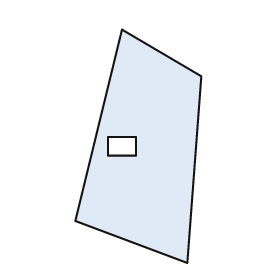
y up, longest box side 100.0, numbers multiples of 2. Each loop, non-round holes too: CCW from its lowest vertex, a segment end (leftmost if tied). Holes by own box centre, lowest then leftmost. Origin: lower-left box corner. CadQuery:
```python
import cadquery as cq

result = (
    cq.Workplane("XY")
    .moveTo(48.0, 0.0)
    .lineTo(54.0, 80.0)
    .lineTo(20.0, 100.0)
    .lineTo(0.0, 18.0)
    .close()
    .moveTo(14.0, 46.0)
    .lineTo(26.0, 46.0)
    .lineTo(26.0, 54.0)
    .lineTo(14.0, 54.0)
    .close()
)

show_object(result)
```